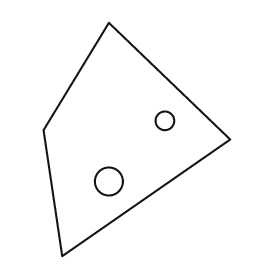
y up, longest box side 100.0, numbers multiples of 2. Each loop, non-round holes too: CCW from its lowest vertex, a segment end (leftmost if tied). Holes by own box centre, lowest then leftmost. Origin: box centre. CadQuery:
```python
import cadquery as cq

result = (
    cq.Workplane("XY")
    .moveTo(-32.0, -50.0)
    .lineTo(40.0, 0.0)
    .lineTo(-12.0, 50.0)
    .lineTo(-40.0, 4.0)
    .close()
    .moveTo(-12.0, -18.0)
    .circle(6.0)
    .moveTo(12.0, 8.0)
    .circle(4.0)
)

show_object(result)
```